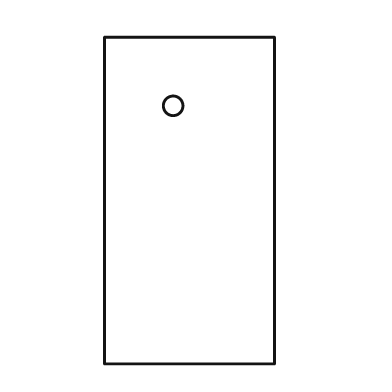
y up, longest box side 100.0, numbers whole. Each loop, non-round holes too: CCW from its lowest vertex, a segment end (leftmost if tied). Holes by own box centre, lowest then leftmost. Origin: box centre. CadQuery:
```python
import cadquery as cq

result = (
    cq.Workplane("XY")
    .moveTo(-26.0, -50.0)
    .lineTo(26.0, -50.0)
    .lineTo(26.0, 50.0)
    .lineTo(-26.0, 50.0)
    .close()
    .moveTo(-5.0, 29.0)
    .circle(3.0)
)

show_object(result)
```